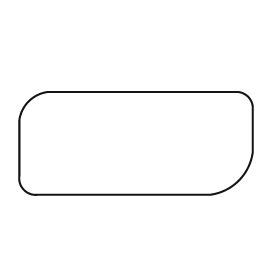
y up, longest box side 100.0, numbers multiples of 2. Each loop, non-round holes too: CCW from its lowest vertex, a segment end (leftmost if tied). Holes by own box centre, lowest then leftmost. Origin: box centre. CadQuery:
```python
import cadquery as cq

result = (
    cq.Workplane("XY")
    .moveTo(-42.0, -22.0)
    .lineTo(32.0, -22.0)
    .threePointArc((44.0, -16.0), (50.0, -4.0))
    .lineTo(50.0, 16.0)
    .threePointArc((48.0, 20.0), (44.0, 22.0))
    .lineTo(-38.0, 22.0)
    .threePointArc((-46.0, 18.0), (-50.0, 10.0))
    .lineTo(-50.0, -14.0)
    .threePointArc((-48.0, -20.0), (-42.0, -22.0))
    .close()
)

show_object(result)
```